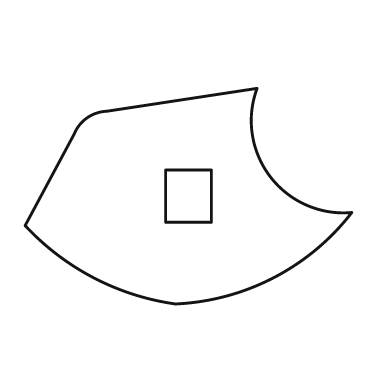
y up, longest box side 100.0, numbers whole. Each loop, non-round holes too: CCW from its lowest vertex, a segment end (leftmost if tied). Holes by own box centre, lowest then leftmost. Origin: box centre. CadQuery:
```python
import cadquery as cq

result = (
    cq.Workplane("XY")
    .moveTo(-4.0, -33.0)
    .threePointArc((26.0, -25.0), (50.0, -5.0))
    .threePointArc((25.0, 6.0), (21.0, 33.0))
    .lineTo(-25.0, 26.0)
    .threePointArc((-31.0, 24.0), (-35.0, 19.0))
    .lineTo(-50.0, -9.0)
    .threePointArc((-29.0, -25.0), (-4.0, -33.0))
    .close()
    .moveTo(-7.0, -8.0)
    .lineTo(7.0, -8.0)
    .lineTo(7.0, 8.0)
    .lineTo(-7.0, 8.0)
    .close()
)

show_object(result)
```